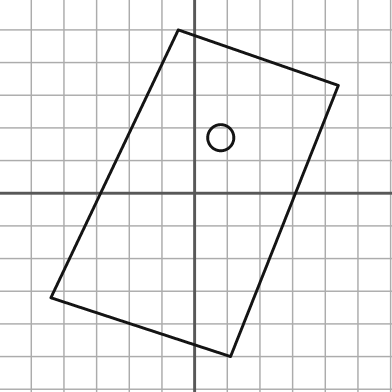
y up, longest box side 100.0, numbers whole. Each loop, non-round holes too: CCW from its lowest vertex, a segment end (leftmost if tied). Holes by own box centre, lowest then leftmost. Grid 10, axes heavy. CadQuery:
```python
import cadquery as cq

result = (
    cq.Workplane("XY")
    .moveTo(11.0, -50.0)
    .lineTo(44.0, 33.0)
    .lineTo(-5.0, 50.0)
    .lineTo(-44.0, -32.0)
    .close()
    .moveTo(8.0, 17.0)
    .circle(4.0)
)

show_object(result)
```